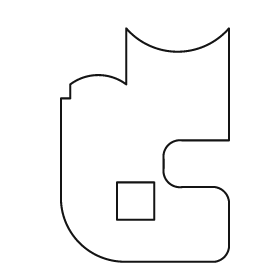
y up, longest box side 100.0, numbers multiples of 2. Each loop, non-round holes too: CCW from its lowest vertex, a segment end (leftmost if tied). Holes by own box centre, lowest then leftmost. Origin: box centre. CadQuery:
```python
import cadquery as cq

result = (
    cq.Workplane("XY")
    .moveTo(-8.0, -50.0)
    .lineTo(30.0, -50.0)
    .threePointArc((34.0, -48.0), (36.0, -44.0))
    .lineTo(36.0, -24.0)
    .threePointArc((34.0, -20.0), (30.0, -18.0))
    .lineTo(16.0, -18.0)
    .threePointArc((10.0, -16.0), (8.0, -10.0))
    .lineTo(8.0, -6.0)
    .threePointArc((10.0, 0.0), (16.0, 2.0))
    .lineTo(36.0, 2.0)
    .lineTo(36.0, 50.0)
    .threePointArc((14.0, 40.0), (-8.0, 50.0))
    .lineTo(-8.0, 26.0)
    .threePointArc((-20.0, 30.0), (-32.0, 26.0))
    .lineTo(-32.0, 20.0)
    .lineTo(-36.0, 20.0)
    .lineTo(-36.0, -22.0)
    .threePointArc((-28.0, -42.0), (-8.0, -50.0))
    .close()
    .moveTo(-12.0, -32.0)
    .lineTo(4.0, -32.0)
    .lineTo(4.0, -16.0)
    .lineTo(-12.0, -16.0)
    .close()
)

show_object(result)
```